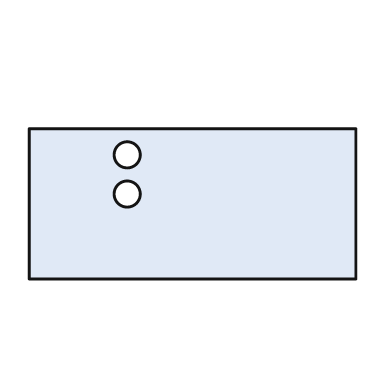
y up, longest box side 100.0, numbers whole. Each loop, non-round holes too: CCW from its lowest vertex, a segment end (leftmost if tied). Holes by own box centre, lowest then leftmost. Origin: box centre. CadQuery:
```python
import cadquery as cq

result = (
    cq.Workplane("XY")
    .moveTo(-50.0, -23.0)
    .lineTo(50.0, -23.0)
    .lineTo(50.0, 23.0)
    .lineTo(-50.0, 23.0)
    .close()
    .moveTo(-20.0, 3.0)
    .circle(4.0)
    .moveTo(-20.0, 15.0)
    .circle(4.0)
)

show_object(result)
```